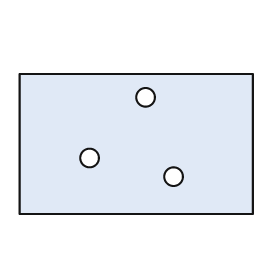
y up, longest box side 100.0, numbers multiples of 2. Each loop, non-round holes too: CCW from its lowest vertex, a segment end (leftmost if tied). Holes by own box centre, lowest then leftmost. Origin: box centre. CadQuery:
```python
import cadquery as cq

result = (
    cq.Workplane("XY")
    .moveTo(-50.0, -30.0)
    .lineTo(50.0, -30.0)
    .lineTo(50.0, 30.0)
    .lineTo(-50.0, 30.0)
    .close()
    .moveTo(16.0, -14.0)
    .circle(4.0)
    .moveTo(-20.0, -6.0)
    .circle(4.0)
    .moveTo(4.0, 20.0)
    .circle(4.0)
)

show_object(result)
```